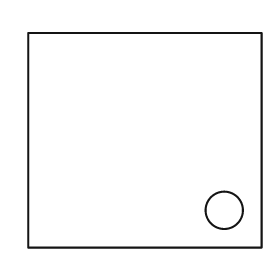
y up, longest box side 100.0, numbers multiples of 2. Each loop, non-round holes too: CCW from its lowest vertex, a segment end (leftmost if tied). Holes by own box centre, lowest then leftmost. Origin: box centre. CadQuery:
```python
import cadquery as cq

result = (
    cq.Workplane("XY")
    .moveTo(-50.0, -46.0)
    .lineTo(50.0, -46.0)
    .lineTo(50.0, 46.0)
    .lineTo(-50.0, 46.0)
    .close()
    .moveTo(34.0, -30.0)
    .circle(8.0)
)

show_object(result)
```